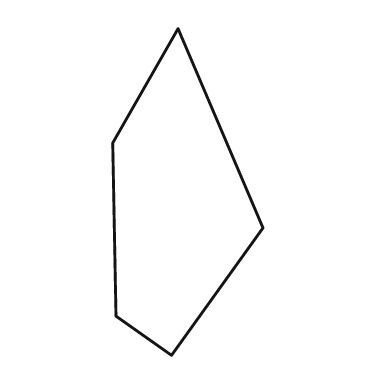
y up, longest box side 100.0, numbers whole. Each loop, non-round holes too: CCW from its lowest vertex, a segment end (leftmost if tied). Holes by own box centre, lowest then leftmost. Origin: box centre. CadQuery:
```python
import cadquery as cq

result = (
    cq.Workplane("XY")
    .moveTo(-5.0, -50.0)
    .lineTo(23.0, -11.0)
    .lineTo(-3.0, 50.0)
    .lineTo(-23.0, 15.0)
    .lineTo(-22.0, -38.0)
    .close()
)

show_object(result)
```